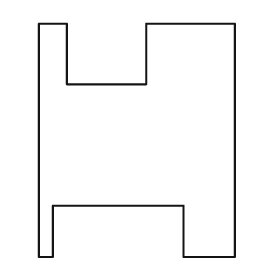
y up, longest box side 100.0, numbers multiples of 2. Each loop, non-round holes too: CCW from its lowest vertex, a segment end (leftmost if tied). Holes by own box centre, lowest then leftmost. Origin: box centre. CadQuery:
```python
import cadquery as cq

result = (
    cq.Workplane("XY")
    .moveTo(-42.0, -50.0)
    .lineTo(-36.0, -50.0)
    .lineTo(-36.0, -28.0)
    .lineTo(20.0, -28.0)
    .lineTo(20.0, -50.0)
    .lineTo(42.0, -50.0)
    .lineTo(42.0, 50.0)
    .lineTo(4.0, 50.0)
    .lineTo(4.0, 24.0)
    .lineTo(-30.0, 24.0)
    .lineTo(-30.0, 50.0)
    .lineTo(-42.0, 50.0)
    .close()
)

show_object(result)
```